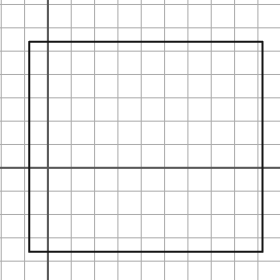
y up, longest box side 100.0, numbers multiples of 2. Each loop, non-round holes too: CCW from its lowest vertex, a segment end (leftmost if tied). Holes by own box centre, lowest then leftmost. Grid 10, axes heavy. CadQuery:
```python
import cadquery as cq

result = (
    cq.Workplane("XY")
    .moveTo(-8.0, -36.0)
    .lineTo(92.0, -36.0)
    .lineTo(92.0, 54.0)
    .lineTo(-8.0, 54.0)
    .close()
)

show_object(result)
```